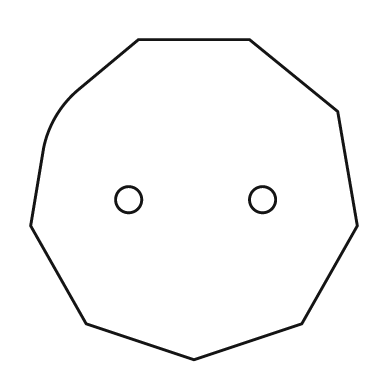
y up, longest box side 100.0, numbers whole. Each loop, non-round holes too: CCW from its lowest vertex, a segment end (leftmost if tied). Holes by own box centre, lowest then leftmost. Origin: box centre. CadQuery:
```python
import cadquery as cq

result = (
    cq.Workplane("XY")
    .moveTo(0.0, -49.0)
    .lineTo(33.0, -38.0)
    .lineTo(50.0, -8.0)
    .lineTo(44.0, 27.0)
    .lineTo(17.0, 49.0)
    .lineTo(-17.0, 49.0)
    .lineTo(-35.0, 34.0)
    .threePointArc((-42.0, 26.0), (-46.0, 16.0))
    .lineTo(-50.0, -8.0)
    .lineTo(-33.0, -38.0)
    .close()
    .moveTo(-20.0, 0.0)
    .circle(4.0)
    .moveTo(21.0, 0.0)
    .circle(4.0)
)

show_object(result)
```